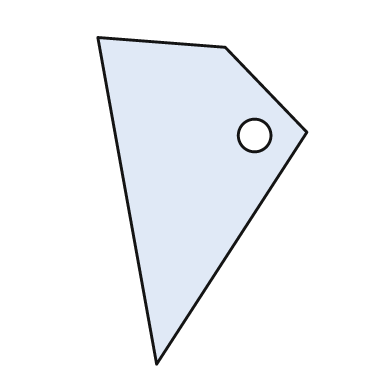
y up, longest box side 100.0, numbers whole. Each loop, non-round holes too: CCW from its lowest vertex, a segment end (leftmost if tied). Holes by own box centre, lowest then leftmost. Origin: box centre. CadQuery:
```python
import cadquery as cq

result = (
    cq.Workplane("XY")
    .moveTo(-14.0, -50.0)
    .lineTo(32.0, 21.0)
    .lineTo(7.0, 47.0)
    .lineTo(-32.0, 50.0)
    .close()
    .moveTo(16.0, 20.0)
    .circle(5.0)
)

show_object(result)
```